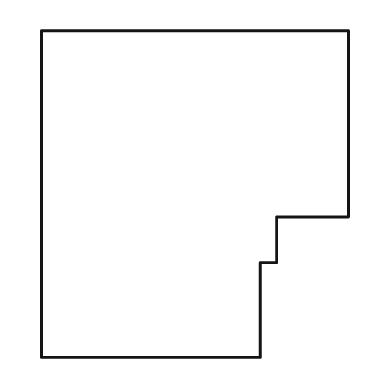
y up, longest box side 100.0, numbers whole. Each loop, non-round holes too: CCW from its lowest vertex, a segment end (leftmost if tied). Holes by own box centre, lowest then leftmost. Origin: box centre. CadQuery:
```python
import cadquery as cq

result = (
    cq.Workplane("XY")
    .moveTo(-47.0, -50.0)
    .lineTo(20.0, -50.0)
    .lineTo(20.0, -21.0)
    .lineTo(25.0, -21.0)
    .lineTo(25.0, -7.0)
    .lineTo(47.0, -7.0)
    .lineTo(47.0, 50.0)
    .lineTo(-47.0, 50.0)
    .close()
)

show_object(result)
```